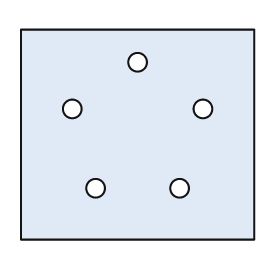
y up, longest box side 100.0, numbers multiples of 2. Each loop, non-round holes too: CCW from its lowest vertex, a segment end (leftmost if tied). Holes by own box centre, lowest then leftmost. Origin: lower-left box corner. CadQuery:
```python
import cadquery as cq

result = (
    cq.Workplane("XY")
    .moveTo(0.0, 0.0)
    .lineTo(100.0, 0.0)
    .lineTo(100.0, 90.0)
    .lineTo(0.0, 90.0)
    .close()
    .moveTo(32.0, 22.0)
    .circle(4.0)
    .moveTo(68.0, 22.0)
    .circle(4.0)
    .moveTo(22.0, 56.0)
    .circle(4.0)
    .moveTo(78.0, 56.0)
    .circle(4.0)
    .moveTo(50.0, 76.0)
    .circle(4.0)
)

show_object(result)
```